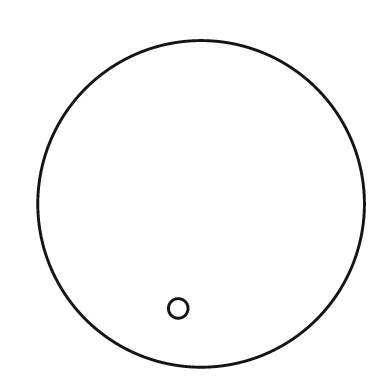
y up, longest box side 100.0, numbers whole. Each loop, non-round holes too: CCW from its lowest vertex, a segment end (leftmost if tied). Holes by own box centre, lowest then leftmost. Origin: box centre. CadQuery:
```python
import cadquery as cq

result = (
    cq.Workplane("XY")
    .moveTo(0.0, 0.0)
    .circle(50.0)
    .moveTo(-7.0, -32.0)
    .circle(3.0)
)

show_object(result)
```